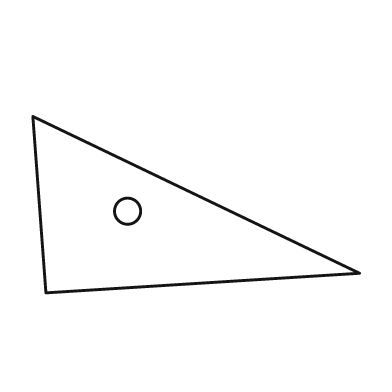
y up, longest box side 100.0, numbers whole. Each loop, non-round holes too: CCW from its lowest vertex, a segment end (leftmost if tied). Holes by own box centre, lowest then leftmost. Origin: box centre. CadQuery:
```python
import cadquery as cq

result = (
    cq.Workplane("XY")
    .moveTo(-46.0, -27.0)
    .lineTo(50.0, -21.0)
    .lineTo(-50.0, 27.0)
    .close()
    .moveTo(-21.0, -2.0)
    .circle(4.0)
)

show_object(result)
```